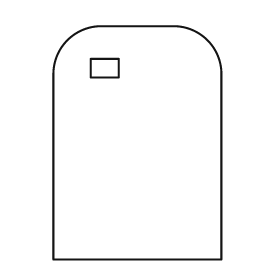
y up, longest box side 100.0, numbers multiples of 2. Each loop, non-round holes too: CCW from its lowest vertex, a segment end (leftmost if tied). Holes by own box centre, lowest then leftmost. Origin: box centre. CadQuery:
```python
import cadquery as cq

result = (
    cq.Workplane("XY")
    .moveTo(-36.0, -50.0)
    .lineTo(36.0, -50.0)
    .lineTo(36.0, 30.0)
    .threePointArc((30.0, 44.0), (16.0, 50.0))
    .lineTo(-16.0, 50.0)
    .threePointArc((-30.0, 44.0), (-36.0, 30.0))
    .close()
    .moveTo(-20.0, 28.0)
    .lineTo(-8.0, 28.0)
    .lineTo(-8.0, 36.0)
    .lineTo(-20.0, 36.0)
    .close()
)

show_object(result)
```